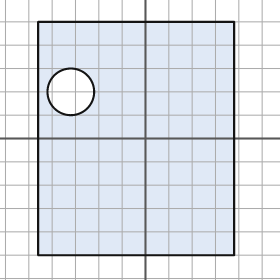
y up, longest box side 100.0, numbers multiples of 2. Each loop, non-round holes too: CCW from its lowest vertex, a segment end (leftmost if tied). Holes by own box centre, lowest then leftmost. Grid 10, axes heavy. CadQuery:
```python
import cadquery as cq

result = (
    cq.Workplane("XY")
    .moveTo(-46.0, -50.0)
    .lineTo(38.0, -50.0)
    .lineTo(38.0, 50.0)
    .lineTo(-46.0, 50.0)
    .close()
    .moveTo(-32.0, 20.0)
    .circle(10.0)
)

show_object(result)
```